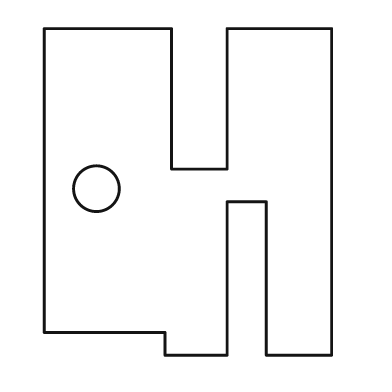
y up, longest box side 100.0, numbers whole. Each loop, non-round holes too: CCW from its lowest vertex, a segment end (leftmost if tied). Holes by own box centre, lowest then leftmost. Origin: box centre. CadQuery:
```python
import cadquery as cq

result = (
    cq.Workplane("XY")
    .moveTo(-7.0, -50.0)
    .lineTo(12.0, -50.0)
    .lineTo(12.0, -3.0)
    .lineTo(24.0, -3.0)
    .lineTo(24.0, -50.0)
    .lineTo(44.0, -50.0)
    .lineTo(44.0, 50.0)
    .lineTo(12.0, 50.0)
    .lineTo(12.0, 7.0)
    .lineTo(-5.0, 7.0)
    .lineTo(-5.0, 50.0)
    .lineTo(-44.0, 50.0)
    .lineTo(-44.0, -43.0)
    .lineTo(-7.0, -43.0)
    .close()
    .moveTo(-28.0, 1.0)
    .circle(7.0)
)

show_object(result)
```